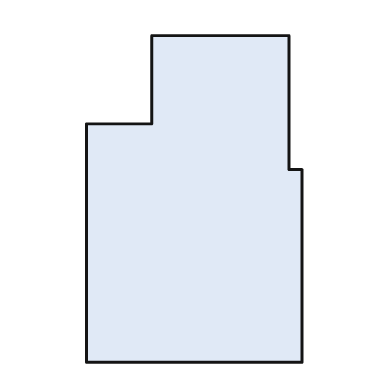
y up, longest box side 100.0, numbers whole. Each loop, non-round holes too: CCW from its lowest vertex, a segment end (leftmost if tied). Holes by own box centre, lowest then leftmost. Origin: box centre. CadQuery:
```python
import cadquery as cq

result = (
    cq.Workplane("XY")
    .moveTo(-33.0, -50.0)
    .lineTo(33.0, -50.0)
    .lineTo(33.0, 9.0)
    .lineTo(29.0, 9.0)
    .lineTo(29.0, 50.0)
    .lineTo(-13.0, 50.0)
    .lineTo(-13.0, 23.0)
    .lineTo(-33.0, 23.0)
    .close()
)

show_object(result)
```